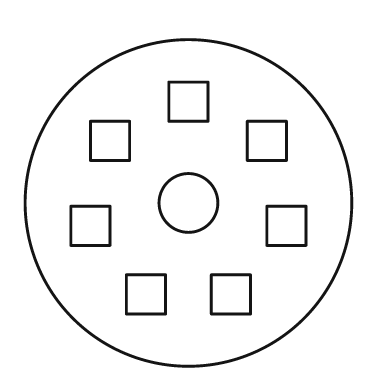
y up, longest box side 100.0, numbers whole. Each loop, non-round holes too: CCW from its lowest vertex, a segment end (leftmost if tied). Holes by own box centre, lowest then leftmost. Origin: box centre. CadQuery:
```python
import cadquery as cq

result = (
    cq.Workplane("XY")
    .moveTo(0.0, 0.0)
    .circle(50.0)
    .moveTo(-19.0, -34.0)
    .lineTo(-7.0, -34.0)
    .lineTo(-7.0, -22.0)
    .lineTo(-19.0, -22.0)
    .close()
    .moveTo(7.0, -34.0)
    .lineTo(19.0, -34.0)
    .lineTo(19.0, -22.0)
    .lineTo(7.0, -22.0)
    .close()
    .moveTo(-36.0, -13.0)
    .lineTo(-24.0, -13.0)
    .lineTo(-24.0, -1.0)
    .lineTo(-36.0, -1.0)
    .close()
    .moveTo(24.0, -13.0)
    .lineTo(36.0, -13.0)
    .lineTo(36.0, -1.0)
    .lineTo(24.0, -1.0)
    .close()
    .moveTo(0.0, 0.0)
    .circle(9.0)
    .moveTo(-30.0, 13.0)
    .lineTo(-18.0, 13.0)
    .lineTo(-18.0, 25.0)
    .lineTo(-30.0, 25.0)
    .close()
    .moveTo(18.0, 13.0)
    .lineTo(30.0, 13.0)
    .lineTo(30.0, 25.0)
    .lineTo(18.0, 25.0)
    .close()
    .moveTo(-6.0, 25.0)
    .lineTo(6.0, 25.0)
    .lineTo(6.0, 37.0)
    .lineTo(-6.0, 37.0)
    .close()
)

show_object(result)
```